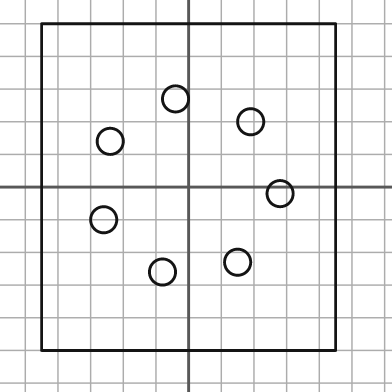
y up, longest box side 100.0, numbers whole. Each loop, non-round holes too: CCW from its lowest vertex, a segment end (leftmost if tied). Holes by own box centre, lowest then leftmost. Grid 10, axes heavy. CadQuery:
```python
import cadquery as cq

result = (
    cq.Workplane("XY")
    .moveTo(-45.0, -50.0)
    .lineTo(45.0, -50.0)
    .lineTo(45.0, 50.0)
    .lineTo(-45.0, 50.0)
    .close()
    .moveTo(-8.0, -26.0)
    .circle(4.0)
    .moveTo(15.0, -23.0)
    .circle(4.0)
    .moveTo(-26.0, -10.0)
    .circle(4.0)
    .moveTo(28.0, -2.0)
    .circle(4.0)
    .moveTo(-24.0, 14.0)
    .circle(4.0)
    .moveTo(19.0, 20.0)
    .circle(4.0)
    .moveTo(-4.0, 27.0)
    .circle(4.0)
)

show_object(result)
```